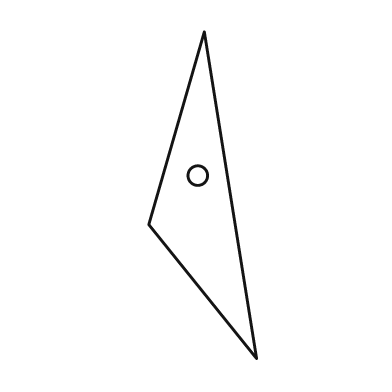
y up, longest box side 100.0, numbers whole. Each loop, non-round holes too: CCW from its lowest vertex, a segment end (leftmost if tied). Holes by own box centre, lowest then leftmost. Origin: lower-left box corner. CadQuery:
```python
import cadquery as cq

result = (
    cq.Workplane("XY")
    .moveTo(33.0, 0.0)
    .lineTo(17.0, 100.0)
    .lineTo(0.0, 41.0)
    .close()
    .moveTo(15.0, 56.0)
    .circle(3.0)
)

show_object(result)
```